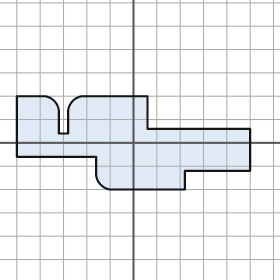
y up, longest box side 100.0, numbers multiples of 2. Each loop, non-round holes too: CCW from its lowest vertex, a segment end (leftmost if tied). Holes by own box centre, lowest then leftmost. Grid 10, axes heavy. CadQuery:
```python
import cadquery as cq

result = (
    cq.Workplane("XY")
    .moveTo(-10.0, -20.0)
    .lineTo(22.0, -20.0)
    .lineTo(22.0, -12.0)
    .lineTo(50.0, -12.0)
    .lineTo(50.0, 6.0)
    .lineTo(6.0, 6.0)
    .lineTo(6.0, 20.0)
    .lineTo(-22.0, 20.0)
    .threePointArc((-26.0, 18.0), (-28.0, 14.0))
    .lineTo(-28.0, 4.0)
    .lineTo(-32.0, 4.0)
    .lineTo(-32.0, 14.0)
    .threePointArc((-34.0, 18.0), (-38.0, 20.0))
    .lineTo(-50.0, 20.0)
    .lineTo(-50.0, -6.0)
    .lineTo(-16.0, -6.0)
    .lineTo(-16.0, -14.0)
    .threePointArc((-14.0, -18.0), (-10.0, -20.0))
    .close()
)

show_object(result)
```